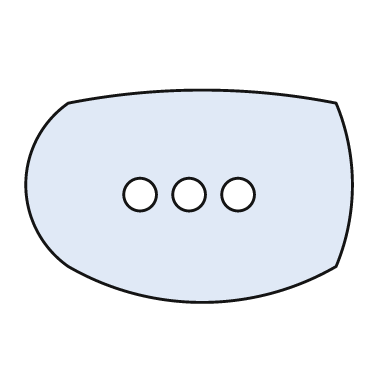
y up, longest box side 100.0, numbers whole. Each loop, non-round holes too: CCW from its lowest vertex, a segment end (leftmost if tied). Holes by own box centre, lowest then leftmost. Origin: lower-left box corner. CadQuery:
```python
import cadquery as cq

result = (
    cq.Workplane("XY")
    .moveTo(13.0, 11.0)
    .threePointArc((54.0, 0.0), (95.0, 11.0))
    .threePointArc((100.0, 36.0), (95.0, 61.0))
    .threePointArc((54.0, 65.0), (13.0, 61.0))
    .threePointArc((0.0, 36.0), (13.0, 11.0))
    .close()
    .moveTo(35.0, 33.0)
    .circle(5.0)
    .moveTo(50.0, 33.0)
    .circle(5.0)
    .moveTo(65.0, 33.0)
    .circle(5.0)
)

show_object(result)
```